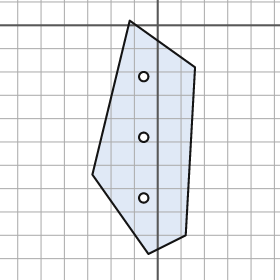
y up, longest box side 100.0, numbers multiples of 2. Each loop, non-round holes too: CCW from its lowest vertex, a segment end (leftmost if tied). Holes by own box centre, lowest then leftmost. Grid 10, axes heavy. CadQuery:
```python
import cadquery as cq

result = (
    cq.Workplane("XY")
    .moveTo(-4.0, -98.0)
    .lineTo(12.0, -90.0)
    .lineTo(16.0, -18.0)
    .lineTo(-12.0, 2.0)
    .lineTo(-28.0, -64.0)
    .close()
    .moveTo(-6.0, -74.0)
    .circle(2.0)
    .moveTo(-6.0, -48.0)
    .circle(2.0)
    .moveTo(-6.0, -22.0)
    .circle(2.0)
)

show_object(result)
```